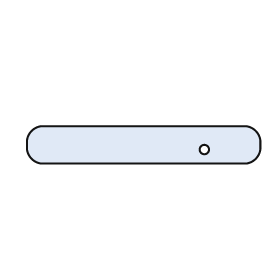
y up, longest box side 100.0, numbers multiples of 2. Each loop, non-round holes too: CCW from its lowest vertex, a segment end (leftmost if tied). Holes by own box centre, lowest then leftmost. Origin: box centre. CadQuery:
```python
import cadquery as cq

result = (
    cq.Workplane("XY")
    .moveTo(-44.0, -8.0)
    .lineTo(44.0, -8.0)
    .threePointArc((48.0, -6.0), (50.0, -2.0))
    .lineTo(50.0, 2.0)
    .threePointArc((48.0, 6.0), (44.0, 8.0))
    .lineTo(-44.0, 8.0)
    .threePointArc((-48.0, 6.0), (-50.0, 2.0))
    .lineTo(-50.0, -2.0)
    .threePointArc((-48.0, -6.0), (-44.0, -8.0))
    .close()
    .moveTo(26.0, -2.0)
    .circle(2.0)
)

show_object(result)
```